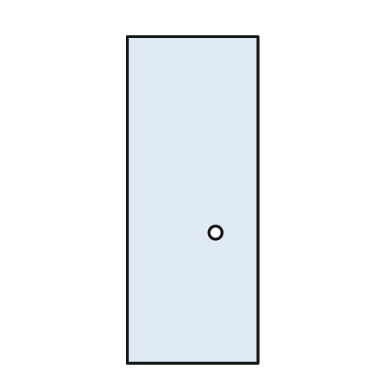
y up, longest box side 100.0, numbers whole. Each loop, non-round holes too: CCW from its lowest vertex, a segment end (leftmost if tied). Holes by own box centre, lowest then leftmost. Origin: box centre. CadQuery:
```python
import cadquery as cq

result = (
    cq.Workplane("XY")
    .moveTo(-20.0, -50.0)
    .lineTo(20.0, -50.0)
    .lineTo(20.0, 50.0)
    .lineTo(-20.0, 50.0)
    .close()
    .moveTo(7.0, -10.0)
    .circle(2.0)
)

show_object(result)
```